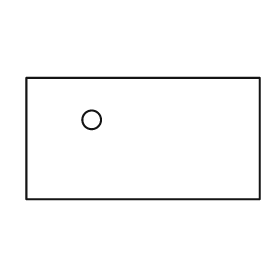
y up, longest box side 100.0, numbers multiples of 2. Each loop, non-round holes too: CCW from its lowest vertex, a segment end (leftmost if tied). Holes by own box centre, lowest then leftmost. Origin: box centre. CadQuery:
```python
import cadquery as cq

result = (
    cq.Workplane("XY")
    .moveTo(-50.0, -26.0)
    .lineTo(50.0, -26.0)
    .lineTo(50.0, 26.0)
    .lineTo(-50.0, 26.0)
    .close()
    .moveTo(-22.0, 8.0)
    .circle(4.0)
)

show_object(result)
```